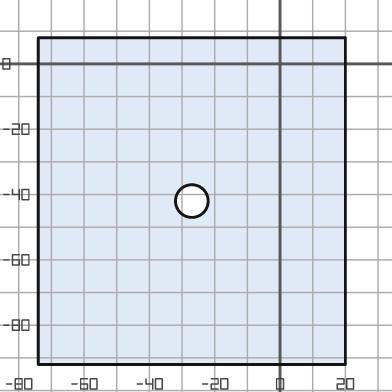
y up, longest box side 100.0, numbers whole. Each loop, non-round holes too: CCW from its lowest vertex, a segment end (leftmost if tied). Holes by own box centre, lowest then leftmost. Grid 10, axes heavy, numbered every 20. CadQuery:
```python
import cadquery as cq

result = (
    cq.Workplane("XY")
    .moveTo(-74.0, -92.0)
    .lineTo(20.0, -92.0)
    .lineTo(20.0, 8.0)
    .lineTo(-74.0, 8.0)
    .close()
    .moveTo(-27.0, -42.0)
    .circle(5.0)
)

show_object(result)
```